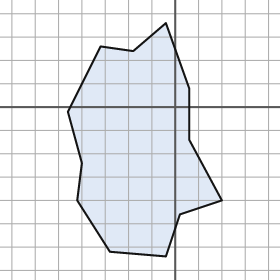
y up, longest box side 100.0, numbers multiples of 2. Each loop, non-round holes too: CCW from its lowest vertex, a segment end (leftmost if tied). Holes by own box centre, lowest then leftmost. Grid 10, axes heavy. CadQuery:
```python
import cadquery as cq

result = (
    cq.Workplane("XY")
    .moveTo(-4.0, -64.0)
    .lineTo(2.0, -46.0)
    .lineTo(20.0, -40.0)
    .lineTo(6.0, -14.0)
    .lineTo(6.0, 8.0)
    .lineTo(-4.0, 36.0)
    .lineTo(-18.0, 24.0)
    .lineTo(-32.0, 26.0)
    .lineTo(-46.0, -2.0)
    .lineTo(-40.0, -24.0)
    .lineTo(-42.0, -40.0)
    .lineTo(-28.0, -62.0)
    .close()
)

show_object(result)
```